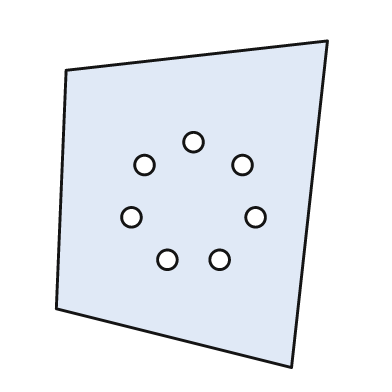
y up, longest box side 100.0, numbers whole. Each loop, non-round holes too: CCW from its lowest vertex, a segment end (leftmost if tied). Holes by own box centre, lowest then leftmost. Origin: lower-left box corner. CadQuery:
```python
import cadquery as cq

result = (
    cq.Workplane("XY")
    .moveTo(72.0, 0.0)
    .lineTo(83.0, 100.0)
    .lineTo(3.0, 91.0)
    .lineTo(0.0, 18.0)
    .close()
    .moveTo(34.0, 33.0)
    .circle(3.0)
    .moveTo(50.0, 33.0)
    .circle(3.0)
    .moveTo(23.0, 46.0)
    .circle(3.0)
    .moveTo(61.0, 46.0)
    .circle(3.0)
    .moveTo(27.0, 62.0)
    .circle(3.0)
    .moveTo(57.0, 62.0)
    .circle(3.0)
    .moveTo(42.0, 69.0)
    .circle(3.0)
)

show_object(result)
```